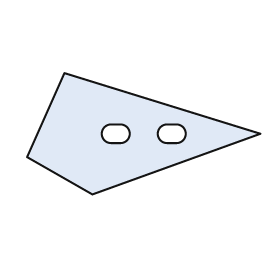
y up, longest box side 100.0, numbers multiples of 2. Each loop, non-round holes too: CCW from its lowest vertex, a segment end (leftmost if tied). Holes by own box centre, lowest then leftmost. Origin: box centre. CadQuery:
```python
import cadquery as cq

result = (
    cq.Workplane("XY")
    .moveTo(-22.0, -26.0)
    .lineTo(50.0, 0.0)
    .lineTo(-34.0, 26.0)
    .lineTo(-50.0, -10.0)
    .close()
    .moveTo(-14.0, -4.0)
    .lineTo(-10.0, -4.0)
    .threePointArc((-6.0, 0.0), (-10.0, 4.0))
    .lineTo(-14.0, 4.0)
    .threePointArc((-18.0, 0.0), (-14.0, -4.0))
    .close()
    .moveTo(10.0, -4.0)
    .lineTo(14.0, -4.0)
    .threePointArc((18.0, 0.0), (14.0, 4.0))
    .lineTo(10.0, 4.0)
    .threePointArc((6.0, 0.0), (10.0, -4.0))
    .close()
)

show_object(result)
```